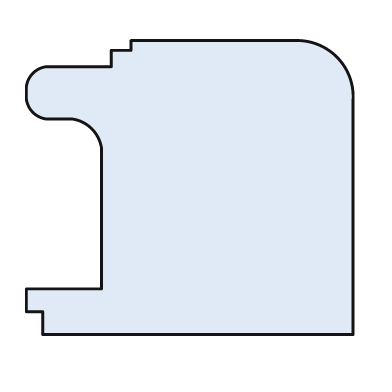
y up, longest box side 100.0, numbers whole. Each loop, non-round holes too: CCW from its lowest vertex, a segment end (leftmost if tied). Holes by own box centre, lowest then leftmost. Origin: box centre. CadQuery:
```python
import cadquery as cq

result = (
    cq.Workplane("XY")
    .moveTo(-45.0, -45.0)
    .lineTo(50.0, -45.0)
    .lineTo(50.0, 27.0)
    .threePointArc((45.0, 40.0), (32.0, 45.0))
    .lineTo(-18.0, 45.0)
    .lineTo(-18.0, 42.0)
    .lineTo(-24.0, 42.0)
    .lineTo(-24.0, 37.0)
    .lineTo(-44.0, 37.0)
    .threePointArc((-48.0, 35.0), (-50.0, 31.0))
    .lineTo(-50.0, 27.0)
    .threePointArc((-48.0, 23.0), (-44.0, 21.0))
    .lineTo(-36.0, 21.0)
    .threePointArc((-30.0, 18.0), (-27.0, 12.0))
    .lineTo(-27.0, -31.0)
    .lineTo(-50.0, -31.0)
    .lineTo(-50.0, -38.0)
    .lineTo(-45.0, -38.0)
    .close()
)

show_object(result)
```